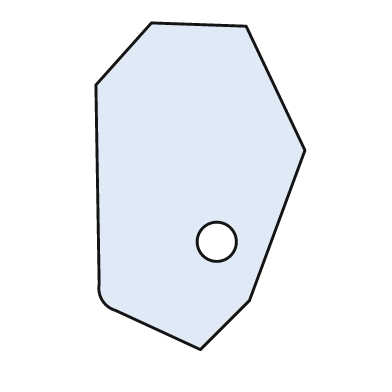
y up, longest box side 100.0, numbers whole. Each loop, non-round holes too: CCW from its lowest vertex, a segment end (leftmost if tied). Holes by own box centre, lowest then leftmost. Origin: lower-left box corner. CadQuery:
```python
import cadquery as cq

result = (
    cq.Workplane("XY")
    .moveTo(32.0, 0.0)
    .lineTo(47.0, 15.0)
    .lineTo(64.0, 61.0)
    .lineTo(46.0, 99.0)
    .lineTo(17.0, 100.0)
    .lineTo(0.0, 81.0)
    .lineTo(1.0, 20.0)
    .threePointArc((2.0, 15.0), (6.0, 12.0))
    .close()
    .moveTo(37.0, 33.0)
    .circle(6.0)
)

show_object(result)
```